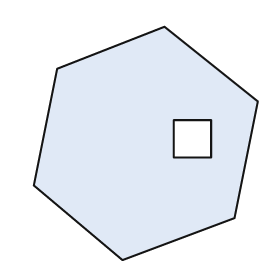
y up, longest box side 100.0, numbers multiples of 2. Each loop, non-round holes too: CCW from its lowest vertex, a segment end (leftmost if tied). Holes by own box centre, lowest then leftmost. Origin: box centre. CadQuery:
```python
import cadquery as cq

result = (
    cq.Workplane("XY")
    .moveTo(-10.0, -50.0)
    .lineTo(38.0, -32.0)
    .lineTo(48.0, 18.0)
    .lineTo(8.0, 50.0)
    .lineTo(-38.0, 32.0)
    .lineTo(-48.0, -18.0)
    .close()
    .moveTo(12.0, -6.0)
    .lineTo(28.0, -6.0)
    .lineTo(28.0, 10.0)
    .lineTo(12.0, 10.0)
    .close()
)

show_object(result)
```